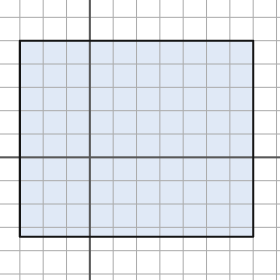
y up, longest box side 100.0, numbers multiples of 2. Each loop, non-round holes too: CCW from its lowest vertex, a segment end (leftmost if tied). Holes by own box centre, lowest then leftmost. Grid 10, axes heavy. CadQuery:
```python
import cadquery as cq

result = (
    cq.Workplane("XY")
    .moveTo(-30.0, -34.0)
    .lineTo(70.0, -34.0)
    .lineTo(70.0, 50.0)
    .lineTo(-30.0, 50.0)
    .close()
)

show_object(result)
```